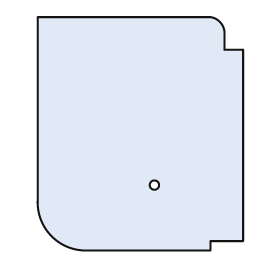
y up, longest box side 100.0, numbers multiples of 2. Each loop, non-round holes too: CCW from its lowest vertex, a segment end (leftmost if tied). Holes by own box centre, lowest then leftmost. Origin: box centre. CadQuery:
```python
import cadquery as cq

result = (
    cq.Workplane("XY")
    .moveTo(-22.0, -50.0)
    .lineTo(30.0, -50.0)
    .lineTo(30.0, -46.0)
    .lineTo(44.0, -46.0)
    .lineTo(44.0, 36.0)
    .lineTo(36.0, 36.0)
    .lineTo(36.0, 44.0)
    .threePointArc((34.0, 48.0), (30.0, 50.0))
    .lineTo(-44.0, 50.0)
    .lineTo(-44.0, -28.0)
    .threePointArc((-38.0, -44.0), (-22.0, -50.0))
    .close()
    .moveTo(6.0, -22.0)
    .circle(2.0)
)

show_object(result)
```